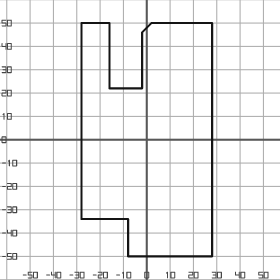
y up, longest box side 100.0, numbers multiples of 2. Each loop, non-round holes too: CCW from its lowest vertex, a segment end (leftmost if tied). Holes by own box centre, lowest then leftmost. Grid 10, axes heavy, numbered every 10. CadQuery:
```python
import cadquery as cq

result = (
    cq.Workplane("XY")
    .moveTo(-8.0, -50.0)
    .lineTo(28.0, -50.0)
    .lineTo(28.0, 50.0)
    .lineTo(2.0, 50.0)
    .lineTo(-2.0, 46.0)
    .lineTo(-2.0, 22.0)
    .lineTo(-16.0, 22.0)
    .lineTo(-16.0, 50.0)
    .lineTo(-28.0, 50.0)
    .lineTo(-28.0, -34.0)
    .lineTo(-8.0, -34.0)
    .close()
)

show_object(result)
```